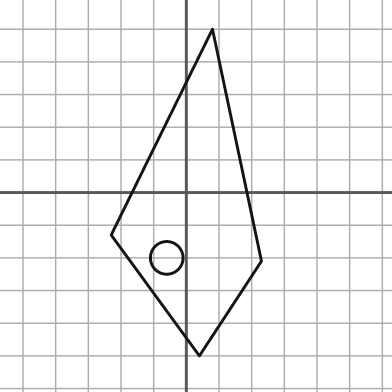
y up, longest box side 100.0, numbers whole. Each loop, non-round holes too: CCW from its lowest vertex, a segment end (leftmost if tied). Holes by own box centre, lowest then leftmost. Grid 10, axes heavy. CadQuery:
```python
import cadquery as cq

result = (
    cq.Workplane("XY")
    .moveTo(4.0, -50.0)
    .lineTo(23.0, -21.0)
    .lineTo(8.0, 50.0)
    .lineTo(-23.0, -13.0)
    .close()
    .moveTo(-6.0, -20.0)
    .circle(5.0)
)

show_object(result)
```